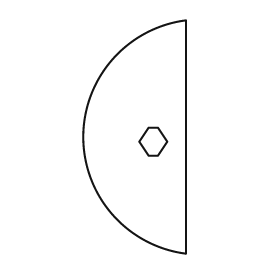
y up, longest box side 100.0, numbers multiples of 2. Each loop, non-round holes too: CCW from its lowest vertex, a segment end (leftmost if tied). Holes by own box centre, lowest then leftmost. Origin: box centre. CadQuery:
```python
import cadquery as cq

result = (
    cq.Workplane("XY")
    .moveTo(22.0, -50.0)
    .lineTo(22.0, 50.0)
    .threePointArc((-22.0, 0.0), (22.0, -50.0))
    .close()
    .moveTo(6.0, -8.0)
    .lineTo(10.0, -8.0)
    .lineTo(14.0, -2.0)
    .lineTo(10.0, 4.0)
    .lineTo(6.0, 4.0)
    .lineTo(2.0, -2.0)
    .close()
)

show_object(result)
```